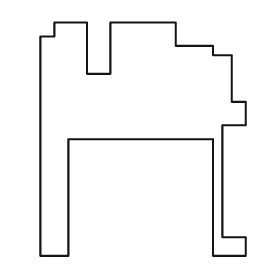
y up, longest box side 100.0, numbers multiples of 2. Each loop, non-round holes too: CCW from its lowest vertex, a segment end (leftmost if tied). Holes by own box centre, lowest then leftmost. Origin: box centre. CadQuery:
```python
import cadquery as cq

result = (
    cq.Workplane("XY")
    .moveTo(-44.0, -50.0)
    .lineTo(-32.0, -50.0)
    .lineTo(-32.0, 0.0)
    .lineTo(30.0, 0.0)
    .lineTo(30.0, -50.0)
    .lineTo(44.0, -50.0)
    .lineTo(44.0, -42.0)
    .lineTo(34.0, -42.0)
    .lineTo(34.0, 6.0)
    .lineTo(44.0, 6.0)
    .lineTo(44.0, 16.0)
    .lineTo(38.0, 16.0)
    .lineTo(38.0, 36.0)
    .lineTo(30.0, 36.0)
    .lineTo(30.0, 40.0)
    .lineTo(14.0, 40.0)
    .lineTo(14.0, 50.0)
    .lineTo(-14.0, 50.0)
    .lineTo(-14.0, 28.0)
    .lineTo(-24.0, 28.0)
    .lineTo(-24.0, 50.0)
    .lineTo(-38.0, 50.0)
    .lineTo(-38.0, 44.0)
    .lineTo(-44.0, 44.0)
    .close()
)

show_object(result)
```